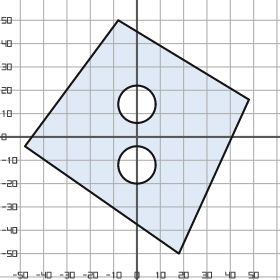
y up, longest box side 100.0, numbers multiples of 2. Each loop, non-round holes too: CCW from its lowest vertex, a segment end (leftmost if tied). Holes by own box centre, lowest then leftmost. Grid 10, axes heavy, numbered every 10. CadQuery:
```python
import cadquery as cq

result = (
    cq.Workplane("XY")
    .moveTo(18.0, -50.0)
    .lineTo(48.0, 16.0)
    .lineTo(-8.0, 50.0)
    .lineTo(-48.0, -4.0)
    .close()
    .moveTo(0.0, -12.0)
    .circle(8.0)
    .moveTo(0.0, 14.0)
    .circle(8.0)
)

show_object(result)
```